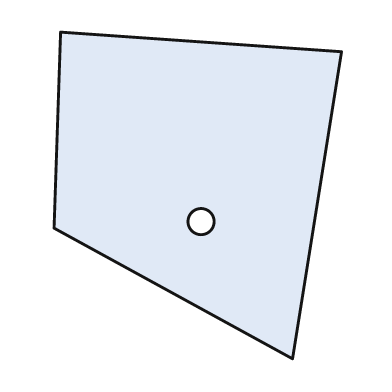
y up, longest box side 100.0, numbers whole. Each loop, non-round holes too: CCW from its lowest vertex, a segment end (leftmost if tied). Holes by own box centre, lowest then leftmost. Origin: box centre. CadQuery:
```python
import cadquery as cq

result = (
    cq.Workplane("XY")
    .moveTo(29.0, -50.0)
    .lineTo(44.0, 44.0)
    .lineTo(-42.0, 50.0)
    .lineTo(-44.0, -10.0)
    .close()
    .moveTo(1.0, -8.0)
    .circle(4.0)
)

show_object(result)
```